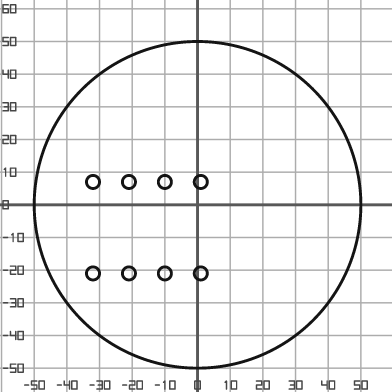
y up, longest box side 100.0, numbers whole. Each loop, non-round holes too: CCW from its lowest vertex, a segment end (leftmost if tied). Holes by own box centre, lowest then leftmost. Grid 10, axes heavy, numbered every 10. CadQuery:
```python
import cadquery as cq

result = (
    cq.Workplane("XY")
    .moveTo(0.0, 0.0)
    .circle(50.0)
    .moveTo(-32.0, -21.0)
    .circle(2.0)
    .moveTo(-21.0, -21.0)
    .circle(2.0)
    .moveTo(-10.0, -21.0)
    .circle(2.0)
    .moveTo(1.0, -21.0)
    .circle(2.0)
    .moveTo(-32.0, 7.0)
    .circle(2.0)
    .moveTo(-21.0, 7.0)
    .circle(2.0)
    .moveTo(-10.0, 7.0)
    .circle(2.0)
    .moveTo(1.0, 7.0)
    .circle(2.0)
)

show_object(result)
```